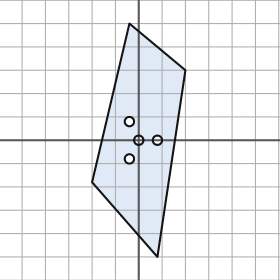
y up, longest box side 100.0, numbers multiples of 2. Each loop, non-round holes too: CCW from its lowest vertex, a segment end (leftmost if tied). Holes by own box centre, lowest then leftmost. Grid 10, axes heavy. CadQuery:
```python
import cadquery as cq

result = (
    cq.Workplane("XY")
    .moveTo(8.0, -50.0)
    .lineTo(20.0, 30.0)
    .lineTo(-4.0, 50.0)
    .lineTo(-20.0, -18.0)
    .close()
    .moveTo(-4.0, -8.0)
    .circle(2.0)
    .moveTo(0.0, 0.0)
    .circle(2.0)
    .moveTo(8.0, 0.0)
    .circle(2.0)
    .moveTo(-4.0, 8.0)
    .circle(2.0)
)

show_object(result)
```